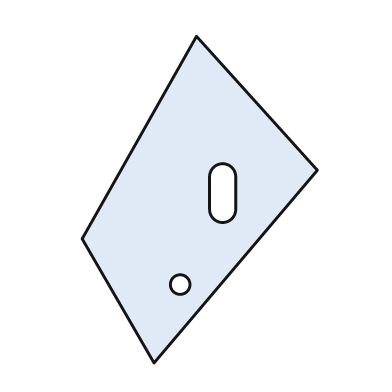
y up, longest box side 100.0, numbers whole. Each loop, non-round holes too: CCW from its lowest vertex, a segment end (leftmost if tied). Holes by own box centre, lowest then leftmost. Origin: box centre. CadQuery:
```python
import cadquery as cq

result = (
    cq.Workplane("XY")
    .moveTo(-14.0, -50.0)
    .lineTo(36.0, 9.0)
    .lineTo(-1.0, 50.0)
    .lineTo(-36.0, -12.0)
    .close()
    .moveTo(-6.0, -26.0)
    .circle(3.0)
    .moveTo(3.0, -3.0)
    .threePointArc((7.0, -7.0), (11.0, -3.0))
    .lineTo(11.0, 7.0)
    .threePointArc((7.0, 11.0), (3.0, 7.0))
    .close()
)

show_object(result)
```